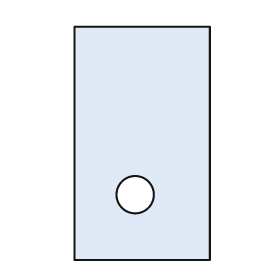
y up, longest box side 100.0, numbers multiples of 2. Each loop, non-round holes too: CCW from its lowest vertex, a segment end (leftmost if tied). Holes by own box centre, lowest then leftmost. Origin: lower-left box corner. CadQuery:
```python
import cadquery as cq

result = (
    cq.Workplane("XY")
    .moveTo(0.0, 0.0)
    .lineTo(58.0, 0.0)
    .lineTo(58.0, 100.0)
    .lineTo(0.0, 100.0)
    .close()
    .moveTo(26.0, 28.0)
    .circle(8.0)
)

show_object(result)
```